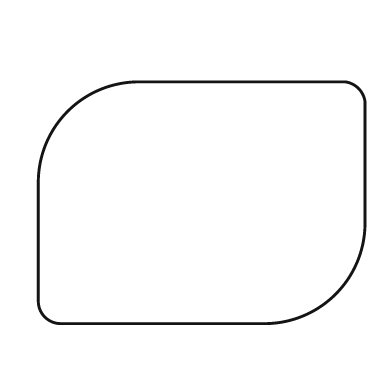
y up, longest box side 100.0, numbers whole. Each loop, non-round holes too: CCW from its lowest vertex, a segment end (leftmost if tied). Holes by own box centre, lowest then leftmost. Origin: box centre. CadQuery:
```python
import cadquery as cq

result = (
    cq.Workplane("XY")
    .moveTo(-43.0, -37.0)
    .lineTo(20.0, -37.0)
    .threePointArc((41.0, -28.0), (50.0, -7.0))
    .lineTo(50.0, 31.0)
    .threePointArc((48.0, 35.0), (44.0, 37.0))
    .lineTo(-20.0, 37.0)
    .threePointArc((-41.0, 28.0), (-50.0, 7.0))
    .lineTo(-50.0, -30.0)
    .threePointArc((-48.0, -35.0), (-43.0, -37.0))
    .close()
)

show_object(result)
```